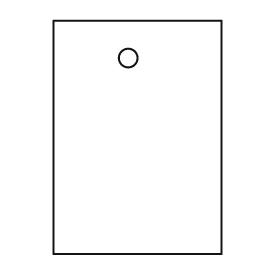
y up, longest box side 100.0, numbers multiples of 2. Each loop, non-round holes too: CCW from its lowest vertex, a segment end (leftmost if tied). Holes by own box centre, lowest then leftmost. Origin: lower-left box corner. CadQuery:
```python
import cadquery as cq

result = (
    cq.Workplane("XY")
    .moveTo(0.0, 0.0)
    .lineTo(72.0, 0.0)
    .lineTo(72.0, 100.0)
    .lineTo(0.0, 100.0)
    .close()
    .moveTo(32.0, 84.0)
    .circle(4.0)
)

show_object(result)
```